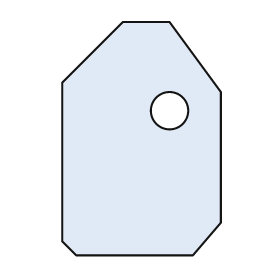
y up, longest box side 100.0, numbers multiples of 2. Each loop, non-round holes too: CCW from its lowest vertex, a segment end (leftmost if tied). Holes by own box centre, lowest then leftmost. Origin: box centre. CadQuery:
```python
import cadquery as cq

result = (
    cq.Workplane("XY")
    .moveTo(-28.0, -50.0)
    .lineTo(22.0, -50.0)
    .lineTo(34.0, -36.0)
    .lineTo(34.0, 20.0)
    .lineTo(12.0, 50.0)
    .lineTo(-8.0, 50.0)
    .lineTo(-34.0, 24.0)
    .lineTo(-34.0, -44.0)
    .close()
    .moveTo(12.0, 12.0)
    .circle(8.0)
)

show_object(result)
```